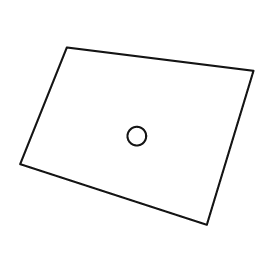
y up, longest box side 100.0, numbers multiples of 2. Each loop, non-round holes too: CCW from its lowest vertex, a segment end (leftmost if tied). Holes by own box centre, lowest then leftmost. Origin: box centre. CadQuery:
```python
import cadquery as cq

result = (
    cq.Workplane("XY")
    .moveTo(30.0, -38.0)
    .lineTo(50.0, 28.0)
    .lineTo(-30.0, 38.0)
    .lineTo(-50.0, -12.0)
    .close()
    .moveTo(0.0, 0.0)
    .circle(4.0)
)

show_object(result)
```